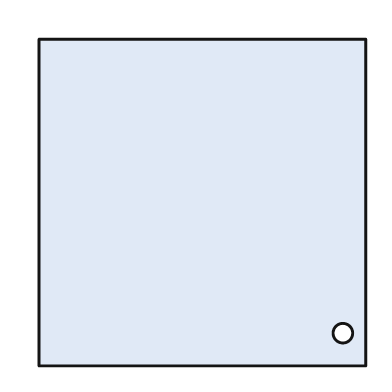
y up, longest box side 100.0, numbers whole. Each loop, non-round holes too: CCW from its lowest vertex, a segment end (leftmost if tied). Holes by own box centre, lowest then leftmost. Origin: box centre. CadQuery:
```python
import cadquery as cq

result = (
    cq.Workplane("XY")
    .moveTo(-50.0, -50.0)
    .lineTo(50.0, -50.0)
    .lineTo(50.0, 50.0)
    .lineTo(-50.0, 50.0)
    .close()
    .moveTo(43.0, -40.0)
    .circle(3.0)
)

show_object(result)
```